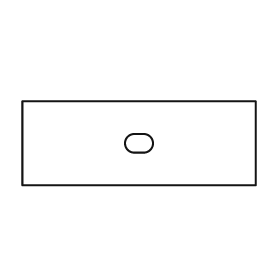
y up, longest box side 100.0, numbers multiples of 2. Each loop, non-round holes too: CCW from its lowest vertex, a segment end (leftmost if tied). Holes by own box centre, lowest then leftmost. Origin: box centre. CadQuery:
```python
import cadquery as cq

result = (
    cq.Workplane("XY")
    .moveTo(-50.0, -18.0)
    .lineTo(50.0, -18.0)
    .lineTo(50.0, 18.0)
    .lineTo(-50.0, 18.0)
    .close()
    .moveTo(-2.0, -4.0)
    .lineTo(2.0, -4.0)
    .threePointArc((6.0, 0.0), (2.0, 4.0))
    .lineTo(-2.0, 4.0)
    .threePointArc((-6.0, 0.0), (-2.0, -4.0))
    .close()
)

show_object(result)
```